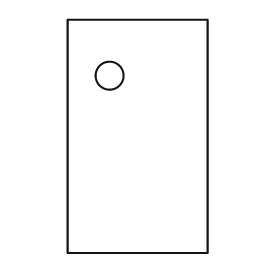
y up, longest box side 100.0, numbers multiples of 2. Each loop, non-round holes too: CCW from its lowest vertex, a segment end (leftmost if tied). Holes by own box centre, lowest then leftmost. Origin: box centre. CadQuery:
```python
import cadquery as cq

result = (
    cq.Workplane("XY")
    .moveTo(-30.0, -50.0)
    .lineTo(30.0, -50.0)
    .lineTo(30.0, 50.0)
    .lineTo(-30.0, 50.0)
    .close()
    .moveTo(-12.0, 26.0)
    .circle(6.0)
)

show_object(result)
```